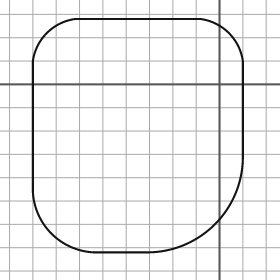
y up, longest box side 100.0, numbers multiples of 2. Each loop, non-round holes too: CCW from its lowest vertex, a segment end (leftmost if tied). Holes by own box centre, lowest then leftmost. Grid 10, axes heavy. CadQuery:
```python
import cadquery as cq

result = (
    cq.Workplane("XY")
    .moveTo(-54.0, -72.0)
    .lineTo(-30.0, -72.0)
    .threePointArc((-2.0, -60.0), (10.0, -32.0))
    .lineTo(10.0, 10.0)
    .threePointArc((4.0, 22.0), (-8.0, 28.0))
    .lineTo(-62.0, 28.0)
    .threePointArc((-74.0, 22.0), (-80.0, 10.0))
    .lineTo(-80.0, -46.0)
    .threePointArc((-72.0, -64.0), (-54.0, -72.0))
    .close()
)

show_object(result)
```